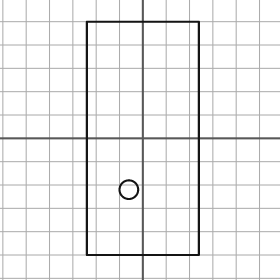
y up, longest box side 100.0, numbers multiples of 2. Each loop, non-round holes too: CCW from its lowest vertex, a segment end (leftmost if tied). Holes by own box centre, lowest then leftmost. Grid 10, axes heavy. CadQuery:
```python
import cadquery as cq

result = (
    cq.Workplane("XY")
    .moveTo(-24.0, -50.0)
    .lineTo(24.0, -50.0)
    .lineTo(24.0, 50.0)
    .lineTo(-24.0, 50.0)
    .close()
    .moveTo(-6.0, -22.0)
    .circle(4.0)
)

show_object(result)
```